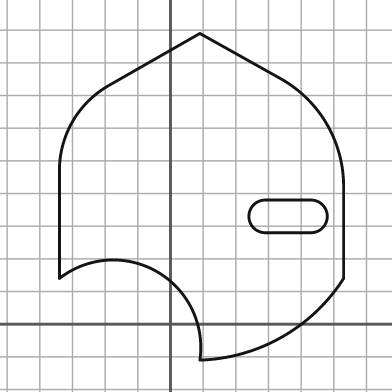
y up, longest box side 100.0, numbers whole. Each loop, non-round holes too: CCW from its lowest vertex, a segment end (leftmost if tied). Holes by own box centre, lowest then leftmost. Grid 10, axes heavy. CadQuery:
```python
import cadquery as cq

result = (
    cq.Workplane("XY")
    .moveTo(9.0, -11.0)
    .threePointArc((34.0, -4.0), (53.0, 14.0))
    .lineTo(53.0, 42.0)
    .threePointArc((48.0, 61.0), (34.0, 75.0))
    .lineTo(9.0, 89.0)
    .lineTo(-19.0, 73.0)
    .threePointArc((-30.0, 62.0), (-34.0, 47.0))
    .lineTo(-34.0, 14.0)
    .threePointArc((-4.0, 16.0), (9.0, -11.0))
    .close()
    .moveTo(29.0, 28.0)
    .lineTo(43.0, 28.0)
    .threePointArc((48.0, 33.0), (43.0, 38.0))
    .lineTo(29.0, 38.0)
    .threePointArc((24.0, 33.0), (29.0, 28.0))
    .close()
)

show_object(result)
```